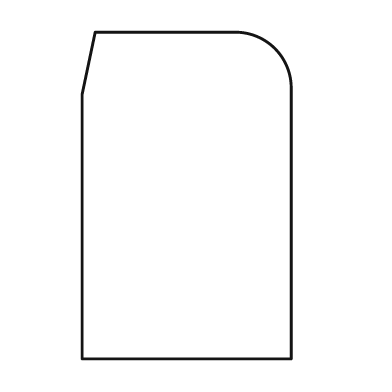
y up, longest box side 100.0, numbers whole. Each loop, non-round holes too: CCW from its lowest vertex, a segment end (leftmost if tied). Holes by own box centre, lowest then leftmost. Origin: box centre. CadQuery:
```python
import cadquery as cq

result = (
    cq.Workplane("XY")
    .moveTo(-32.0, -50.0)
    .lineTo(32.0, -50.0)
    .lineTo(32.0, 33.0)
    .threePointArc((27.0, 45.0), (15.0, 50.0))
    .lineTo(-28.0, 50.0)
    .lineTo(-32.0, 31.0)
    .close()
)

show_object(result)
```